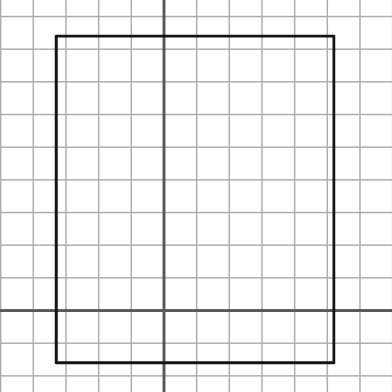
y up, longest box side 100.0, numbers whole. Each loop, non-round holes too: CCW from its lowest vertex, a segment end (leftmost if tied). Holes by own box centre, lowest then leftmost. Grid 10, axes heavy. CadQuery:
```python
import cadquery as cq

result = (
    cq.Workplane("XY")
    .moveTo(-33.0, -16.0)
    .lineTo(52.0, -16.0)
    .lineTo(52.0, 84.0)
    .lineTo(-33.0, 84.0)
    .close()
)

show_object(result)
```